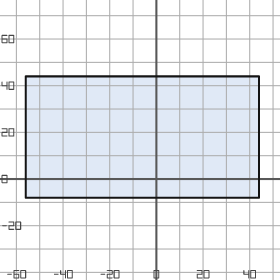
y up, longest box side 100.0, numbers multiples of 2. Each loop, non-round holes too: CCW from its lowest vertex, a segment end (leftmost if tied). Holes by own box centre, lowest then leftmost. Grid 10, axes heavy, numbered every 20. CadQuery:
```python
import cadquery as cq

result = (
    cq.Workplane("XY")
    .moveTo(-56.0, -8.0)
    .lineTo(44.0, -8.0)
    .lineTo(44.0, 44.0)
    .lineTo(-56.0, 44.0)
    .close()
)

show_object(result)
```